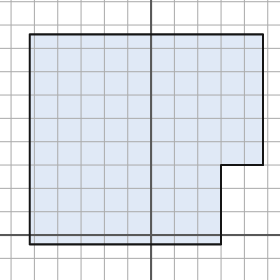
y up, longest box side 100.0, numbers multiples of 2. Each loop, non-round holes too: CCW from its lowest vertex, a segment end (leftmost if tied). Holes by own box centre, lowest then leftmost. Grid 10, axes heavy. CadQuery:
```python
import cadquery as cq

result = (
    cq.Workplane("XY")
    .moveTo(-52.0, -4.0)
    .lineTo(30.0, -4.0)
    .lineTo(30.0, 30.0)
    .lineTo(48.0, 30.0)
    .lineTo(48.0, 86.0)
    .lineTo(-52.0, 86.0)
    .close()
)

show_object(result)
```